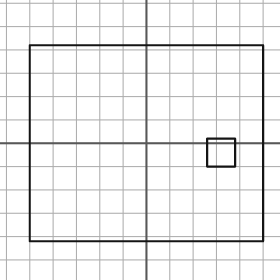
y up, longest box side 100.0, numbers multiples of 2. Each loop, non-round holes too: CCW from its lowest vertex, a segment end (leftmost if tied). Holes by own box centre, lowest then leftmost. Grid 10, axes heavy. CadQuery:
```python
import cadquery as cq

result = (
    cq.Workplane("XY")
    .moveTo(-50.0, -42.0)
    .lineTo(50.0, -42.0)
    .lineTo(50.0, 42.0)
    .lineTo(-50.0, 42.0)
    .close()
    .moveTo(26.0, -10.0)
    .lineTo(38.0, -10.0)
    .lineTo(38.0, 2.0)
    .lineTo(26.0, 2.0)
    .close()
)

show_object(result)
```